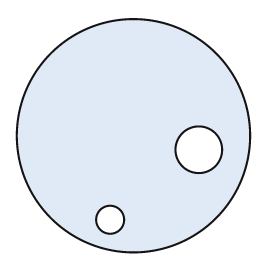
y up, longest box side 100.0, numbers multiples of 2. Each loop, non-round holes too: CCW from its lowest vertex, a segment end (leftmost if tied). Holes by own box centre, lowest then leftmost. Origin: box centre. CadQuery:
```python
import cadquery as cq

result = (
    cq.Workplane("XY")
    .moveTo(0.0, 0.0)
    .circle(50.0)
    .moveTo(-10.0, -36.0)
    .circle(6.0)
    .moveTo(28.0, -6.0)
    .circle(10.0)
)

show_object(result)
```